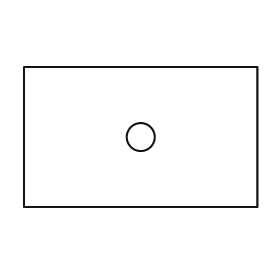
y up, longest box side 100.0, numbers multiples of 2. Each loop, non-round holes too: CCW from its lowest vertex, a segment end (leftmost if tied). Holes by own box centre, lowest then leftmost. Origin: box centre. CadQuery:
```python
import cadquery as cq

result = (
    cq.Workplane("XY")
    .moveTo(-50.0, -30.0)
    .lineTo(50.0, -30.0)
    .lineTo(50.0, 30.0)
    .lineTo(-50.0, 30.0)
    .close()
    .moveTo(0.0, 0.0)
    .circle(6.0)
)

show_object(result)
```